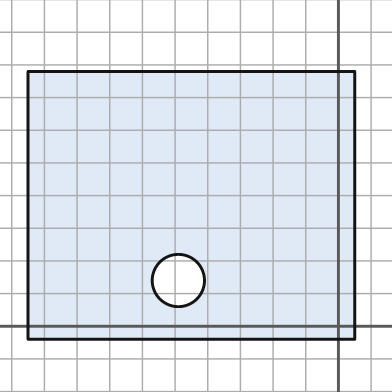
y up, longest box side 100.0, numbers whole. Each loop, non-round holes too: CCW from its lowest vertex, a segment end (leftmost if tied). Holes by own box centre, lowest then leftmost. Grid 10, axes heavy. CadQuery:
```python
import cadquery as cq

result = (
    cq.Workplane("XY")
    .moveTo(-95.0, -4.0)
    .lineTo(5.0, -4.0)
    .lineTo(5.0, 78.0)
    .lineTo(-95.0, 78.0)
    .close()
    .moveTo(-49.0, 14.0)
    .circle(8.0)
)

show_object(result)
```